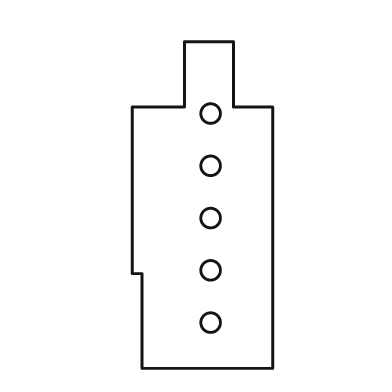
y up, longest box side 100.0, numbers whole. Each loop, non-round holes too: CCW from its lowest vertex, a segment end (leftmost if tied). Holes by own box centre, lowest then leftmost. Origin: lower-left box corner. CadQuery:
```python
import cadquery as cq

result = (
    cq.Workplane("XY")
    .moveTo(3.0, 0.0)
    .lineTo(43.0, 0.0)
    .lineTo(43.0, 80.0)
    .lineTo(31.0, 80.0)
    .lineTo(31.0, 100.0)
    .lineTo(16.0, 100.0)
    .lineTo(16.0, 80.0)
    .lineTo(0.0, 80.0)
    .lineTo(0.0, 29.0)
    .lineTo(3.0, 29.0)
    .close()
    .moveTo(24.0, 14.0)
    .circle(3.0)
    .moveTo(24.0, 30.0)
    .circle(3.0)
    .moveTo(24.0, 46.0)
    .circle(3.0)
    .moveTo(24.0, 62.0)
    .circle(3.0)
    .moveTo(24.0, 78.0)
    .circle(3.0)
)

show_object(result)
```